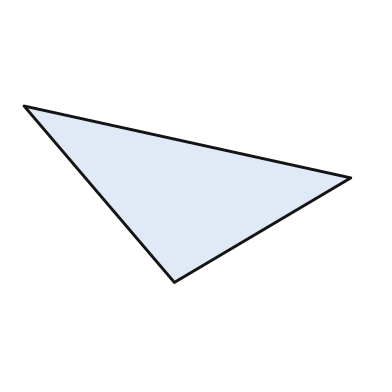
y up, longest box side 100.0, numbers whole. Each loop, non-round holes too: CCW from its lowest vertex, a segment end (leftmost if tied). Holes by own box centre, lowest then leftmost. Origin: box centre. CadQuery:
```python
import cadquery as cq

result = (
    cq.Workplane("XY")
    .moveTo(-4.0, -27.0)
    .lineTo(50.0, 5.0)
    .lineTo(-50.0, 27.0)
    .close()
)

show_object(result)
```